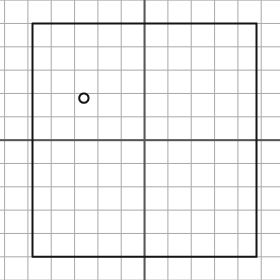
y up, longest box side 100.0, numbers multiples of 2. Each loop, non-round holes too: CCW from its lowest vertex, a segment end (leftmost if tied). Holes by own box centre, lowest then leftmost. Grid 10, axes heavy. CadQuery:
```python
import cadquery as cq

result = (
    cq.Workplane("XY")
    .moveTo(-48.0, -50.0)
    .lineTo(48.0, -50.0)
    .lineTo(48.0, 50.0)
    .lineTo(-48.0, 50.0)
    .close()
    .moveTo(-26.0, 18.0)
    .circle(2.0)
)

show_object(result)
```